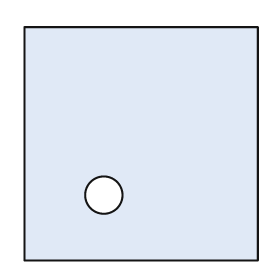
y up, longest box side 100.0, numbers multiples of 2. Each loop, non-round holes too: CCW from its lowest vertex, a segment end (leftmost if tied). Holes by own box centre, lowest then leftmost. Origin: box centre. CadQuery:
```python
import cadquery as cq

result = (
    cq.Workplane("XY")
    .moveTo(-50.0, -50.0)
    .lineTo(50.0, -50.0)
    .lineTo(50.0, 50.0)
    .lineTo(-50.0, 50.0)
    .close()
    .moveTo(-16.0, -22.0)
    .circle(8.0)
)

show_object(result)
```